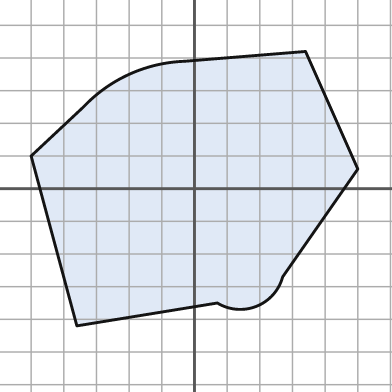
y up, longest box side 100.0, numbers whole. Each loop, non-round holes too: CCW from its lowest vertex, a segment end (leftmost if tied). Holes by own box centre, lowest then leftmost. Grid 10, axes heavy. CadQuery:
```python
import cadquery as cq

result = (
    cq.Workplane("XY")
    .moveTo(-36.0, -42.0)
    .lineTo(7.0, -35.0)
    .threePointArc((19.0, -36.0), (27.0, -27.0))
    .lineTo(50.0, 6.0)
    .lineTo(34.0, 42.0)
    .lineTo(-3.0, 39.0)
    .threePointArc((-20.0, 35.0), (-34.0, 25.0))
    .lineTo(-50.0, 10.0)
    .close()
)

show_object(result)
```